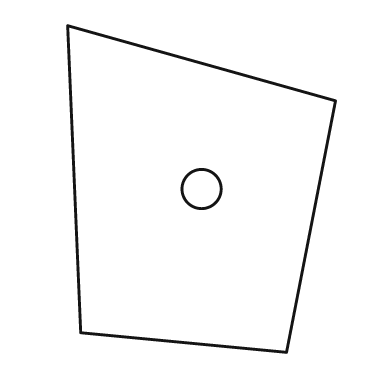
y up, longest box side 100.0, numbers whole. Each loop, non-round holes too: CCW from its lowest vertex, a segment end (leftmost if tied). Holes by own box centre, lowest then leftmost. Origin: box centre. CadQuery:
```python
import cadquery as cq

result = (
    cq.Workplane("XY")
    .moveTo(26.0, -50.0)
    .lineTo(41.0, 27.0)
    .lineTo(-41.0, 50.0)
    .lineTo(-37.0, -44.0)
    .close()
    .moveTo(0.0, 0.0)
    .circle(6.0)
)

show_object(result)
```